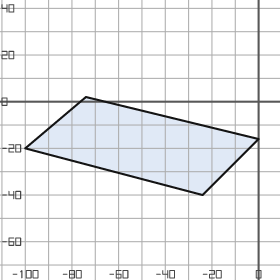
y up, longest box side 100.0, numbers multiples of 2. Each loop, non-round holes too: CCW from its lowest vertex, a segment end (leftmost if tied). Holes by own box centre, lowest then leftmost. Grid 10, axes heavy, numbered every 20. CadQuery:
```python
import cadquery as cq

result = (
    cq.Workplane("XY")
    .moveTo(-24.0, -40.0)
    .lineTo(0.0, -16.0)
    .lineTo(-74.0, 2.0)
    .lineTo(-100.0, -20.0)
    .close()
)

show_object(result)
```